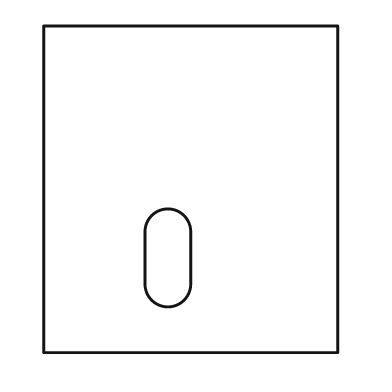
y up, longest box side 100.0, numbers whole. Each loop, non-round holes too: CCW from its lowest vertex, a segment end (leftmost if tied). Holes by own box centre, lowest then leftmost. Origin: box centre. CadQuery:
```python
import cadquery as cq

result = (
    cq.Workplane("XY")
    .moveTo(-45.0, -50.0)
    .lineTo(45.0, -50.0)
    .lineTo(45.0, 50.0)
    .lineTo(-45.0, 50.0)
    .close()
    .moveTo(-14.0, -29.0)
    .threePointArc((-7.0, -36.0), (0.0, -29.0))
    .lineTo(0.0, -13.0)
    .threePointArc((-7.0, -6.0), (-14.0, -13.0))
    .close()
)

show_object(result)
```